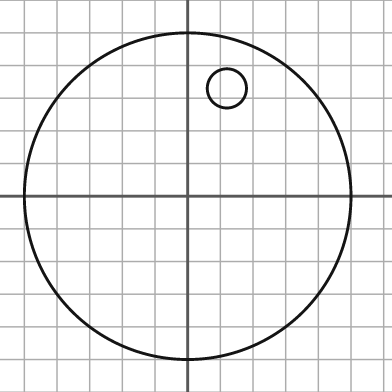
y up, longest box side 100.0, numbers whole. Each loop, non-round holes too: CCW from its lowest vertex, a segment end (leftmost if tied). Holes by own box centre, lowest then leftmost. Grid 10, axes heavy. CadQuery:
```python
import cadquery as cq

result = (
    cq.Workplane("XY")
    .moveTo(0.0, 0.0)
    .circle(50.0)
    .moveTo(12.0, 33.0)
    .circle(6.0)
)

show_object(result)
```